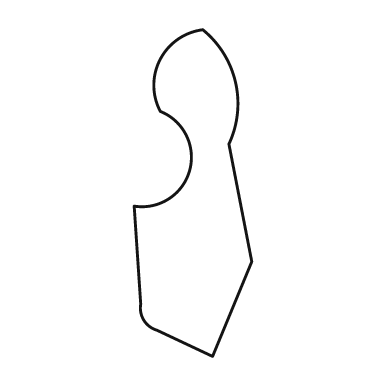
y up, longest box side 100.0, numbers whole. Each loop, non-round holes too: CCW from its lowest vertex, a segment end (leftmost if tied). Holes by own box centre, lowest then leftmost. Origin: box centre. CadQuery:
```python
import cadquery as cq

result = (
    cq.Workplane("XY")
    .moveTo(6.0, -50.0)
    .lineTo(18.0, -21.0)
    .lineTo(11.0, 15.0)
    .threePointArc((13.0, 34.0), (3.0, 50.0))
    .threePointArc((-10.0, 41.0), (-10.0, 25.0))
    .threePointArc((-1.0, 7.0), (-18.0, -4.0))
    .lineTo(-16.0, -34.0)
    .threePointArc((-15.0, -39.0), (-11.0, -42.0))
    .close()
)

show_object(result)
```